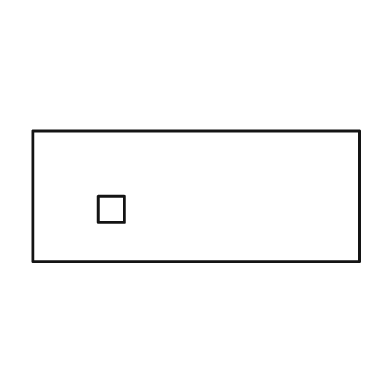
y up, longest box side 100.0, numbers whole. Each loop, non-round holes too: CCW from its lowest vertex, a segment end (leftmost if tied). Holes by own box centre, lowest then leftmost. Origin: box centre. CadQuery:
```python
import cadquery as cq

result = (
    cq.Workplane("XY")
    .moveTo(-50.0, -20.0)
    .lineTo(50.0, -20.0)
    .lineTo(50.0, 20.0)
    .lineTo(-50.0, 20.0)
    .close()
    .moveTo(-30.0, -8.0)
    .lineTo(-22.0, -8.0)
    .lineTo(-22.0, 0.0)
    .lineTo(-30.0, 0.0)
    .close()
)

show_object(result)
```